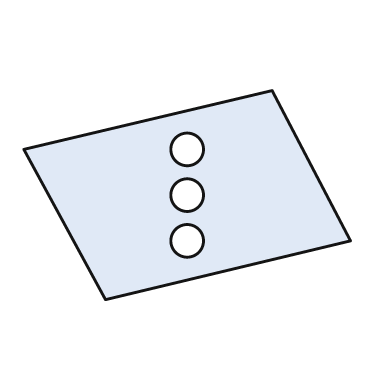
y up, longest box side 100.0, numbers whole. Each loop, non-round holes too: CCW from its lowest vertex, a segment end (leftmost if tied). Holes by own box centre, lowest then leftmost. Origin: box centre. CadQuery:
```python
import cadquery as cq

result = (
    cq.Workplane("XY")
    .moveTo(-25.0, -32.0)
    .lineTo(50.0, -14.0)
    .lineTo(26.0, 32.0)
    .lineTo(-50.0, 14.0)
    .close()
    .moveTo(0.0, -14.0)
    .circle(5.0)
    .moveTo(0.0, 0.0)
    .circle(5.0)
    .moveTo(0.0, 14.0)
    .circle(5.0)
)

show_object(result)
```